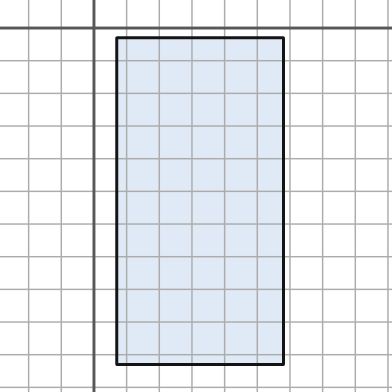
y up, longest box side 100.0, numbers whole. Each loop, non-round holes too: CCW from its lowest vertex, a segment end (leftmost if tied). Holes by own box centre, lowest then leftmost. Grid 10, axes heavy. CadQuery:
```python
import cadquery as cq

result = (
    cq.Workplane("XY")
    .moveTo(7.0, -103.0)
    .lineTo(58.0, -103.0)
    .lineTo(58.0, -3.0)
    .lineTo(7.0, -3.0)
    .close()
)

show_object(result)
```